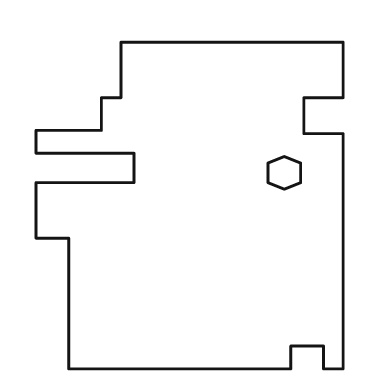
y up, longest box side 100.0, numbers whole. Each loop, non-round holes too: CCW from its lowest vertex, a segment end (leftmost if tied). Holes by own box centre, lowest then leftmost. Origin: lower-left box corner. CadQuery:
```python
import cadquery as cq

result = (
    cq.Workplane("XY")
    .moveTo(10.0, 0.0)
    .lineTo(78.0, 0.0)
    .lineTo(78.0, 7.0)
    .lineTo(88.0, 7.0)
    .lineTo(88.0, 0.0)
    .lineTo(94.0, 0.0)
    .lineTo(94.0, 72.0)
    .lineTo(82.0, 72.0)
    .lineTo(82.0, 83.0)
    .lineTo(94.0, 83.0)
    .lineTo(94.0, 100.0)
    .lineTo(26.0, 100.0)
    .lineTo(26.0, 83.0)
    .lineTo(20.0, 83.0)
    .lineTo(20.0, 73.0)
    .lineTo(0.0, 73.0)
    .lineTo(0.0, 66.0)
    .lineTo(30.0, 66.0)
    .lineTo(30.0, 57.0)
    .lineTo(0.0, 57.0)
    .lineTo(0.0, 40.0)
    .lineTo(10.0, 40.0)
    .close()
    .moveTo(76.0, 55.0)
    .lineTo(81.0, 57.0)
    .lineTo(81.0, 63.0)
    .lineTo(76.0, 65.0)
    .lineTo(71.0, 63.0)
    .lineTo(71.0, 57.0)
    .close()
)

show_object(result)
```